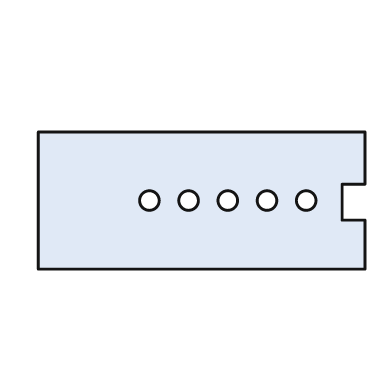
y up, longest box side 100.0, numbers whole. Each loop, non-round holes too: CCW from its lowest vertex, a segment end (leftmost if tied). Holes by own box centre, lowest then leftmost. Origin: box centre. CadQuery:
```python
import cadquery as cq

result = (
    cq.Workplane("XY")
    .moveTo(-50.0, -21.0)
    .lineTo(50.0, -21.0)
    .lineTo(50.0, -6.0)
    .lineTo(43.0, -6.0)
    .lineTo(43.0, 5.0)
    .lineTo(50.0, 5.0)
    .lineTo(50.0, 21.0)
    .lineTo(-50.0, 21.0)
    .close()
    .moveTo(-16.0, 0.0)
    .circle(3.0)
    .moveTo(-4.0, 0.0)
    .circle(3.0)
    .moveTo(8.0, 0.0)
    .circle(3.0)
    .moveTo(20.0, 0.0)
    .circle(3.0)
    .moveTo(32.0, 0.0)
    .circle(3.0)
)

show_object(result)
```